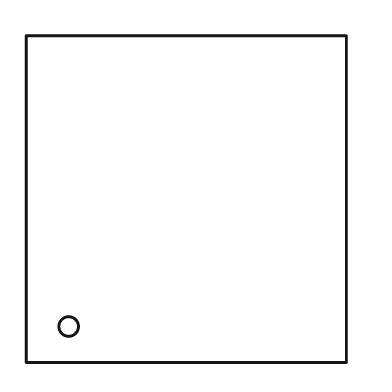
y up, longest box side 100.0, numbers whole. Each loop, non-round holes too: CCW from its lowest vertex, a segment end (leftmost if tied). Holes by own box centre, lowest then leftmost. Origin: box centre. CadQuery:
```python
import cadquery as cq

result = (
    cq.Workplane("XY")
    .moveTo(-49.0, -50.0)
    .lineTo(49.0, -50.0)
    .lineTo(49.0, 50.0)
    .lineTo(-49.0, 50.0)
    .close()
    .moveTo(-36.0, -39.0)
    .circle(3.0)
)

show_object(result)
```